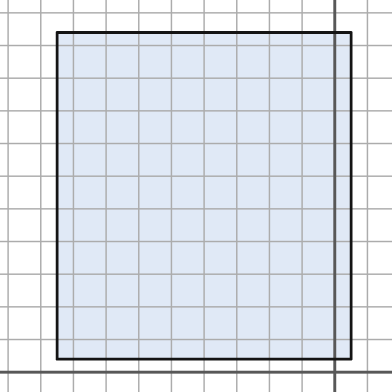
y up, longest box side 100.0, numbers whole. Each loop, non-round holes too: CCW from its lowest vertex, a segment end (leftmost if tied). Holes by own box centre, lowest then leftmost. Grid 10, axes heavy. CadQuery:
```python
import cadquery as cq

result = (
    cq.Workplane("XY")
    .moveTo(-85.0, 4.0)
    .lineTo(5.0, 4.0)
    .lineTo(5.0, 104.0)
    .lineTo(-85.0, 104.0)
    .close()
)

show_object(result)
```